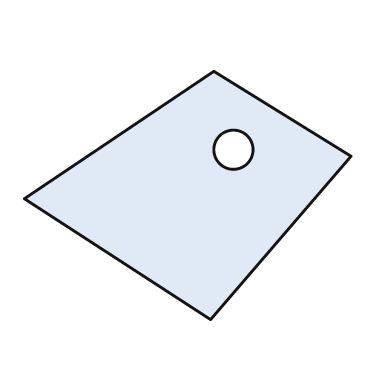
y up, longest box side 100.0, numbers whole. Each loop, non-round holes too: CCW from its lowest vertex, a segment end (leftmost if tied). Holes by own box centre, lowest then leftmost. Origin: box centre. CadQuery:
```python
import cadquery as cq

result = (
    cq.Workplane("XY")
    .moveTo(7.0, -38.0)
    .lineTo(50.0, 12.0)
    .lineTo(8.0, 38.0)
    .lineTo(-50.0, -1.0)
    .close()
    .moveTo(14.0, 14.0)
    .circle(6.0)
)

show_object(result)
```